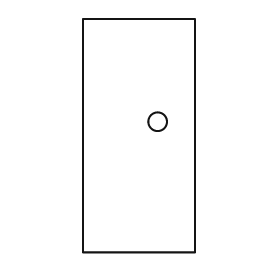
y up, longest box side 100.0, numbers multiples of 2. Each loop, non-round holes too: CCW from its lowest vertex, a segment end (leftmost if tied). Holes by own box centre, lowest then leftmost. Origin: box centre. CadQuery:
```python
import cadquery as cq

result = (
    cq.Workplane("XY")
    .moveTo(-24.0, -50.0)
    .lineTo(24.0, -50.0)
    .lineTo(24.0, 50.0)
    .lineTo(-24.0, 50.0)
    .close()
    .moveTo(8.0, 6.0)
    .circle(4.0)
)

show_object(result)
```